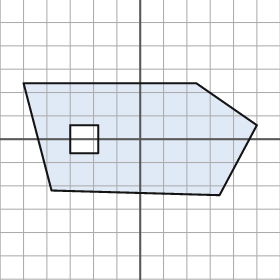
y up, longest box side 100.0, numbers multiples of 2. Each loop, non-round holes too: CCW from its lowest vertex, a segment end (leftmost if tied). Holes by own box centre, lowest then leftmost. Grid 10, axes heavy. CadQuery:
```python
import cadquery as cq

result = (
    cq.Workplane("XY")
    .moveTo(34.0, -24.0)
    .lineTo(50.0, 6.0)
    .lineTo(24.0, 24.0)
    .lineTo(-50.0, 24.0)
    .lineTo(-38.0, -22.0)
    .close()
    .moveTo(-30.0, -6.0)
    .lineTo(-18.0, -6.0)
    .lineTo(-18.0, 6.0)
    .lineTo(-30.0, 6.0)
    .close()
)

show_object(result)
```